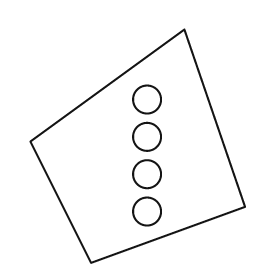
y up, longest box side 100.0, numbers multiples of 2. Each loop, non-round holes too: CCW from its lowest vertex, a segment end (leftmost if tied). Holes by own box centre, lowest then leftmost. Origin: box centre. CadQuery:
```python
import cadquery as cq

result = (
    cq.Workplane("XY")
    .moveTo(-20.0, -50.0)
    .lineTo(46.0, -26.0)
    .lineTo(20.0, 50.0)
    .lineTo(-46.0, 2.0)
    .close()
    .moveTo(4.0, -28.0)
    .circle(6.0)
    .moveTo(4.0, -12.0)
    .circle(6.0)
    .moveTo(4.0, 4.0)
    .circle(6.0)
    .moveTo(4.0, 20.0)
    .circle(6.0)
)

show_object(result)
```